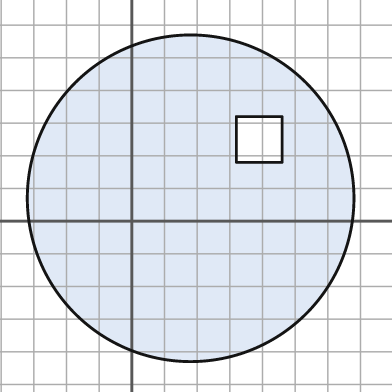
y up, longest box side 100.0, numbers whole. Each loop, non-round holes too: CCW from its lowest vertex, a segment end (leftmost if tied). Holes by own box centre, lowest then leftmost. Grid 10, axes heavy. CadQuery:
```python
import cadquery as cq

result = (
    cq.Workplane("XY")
    .moveTo(18.0, 7.0)
    .circle(50.0)
    .moveTo(32.0, 18.0)
    .lineTo(46.0, 18.0)
    .lineTo(46.0, 32.0)
    .lineTo(32.0, 32.0)
    .close()
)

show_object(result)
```